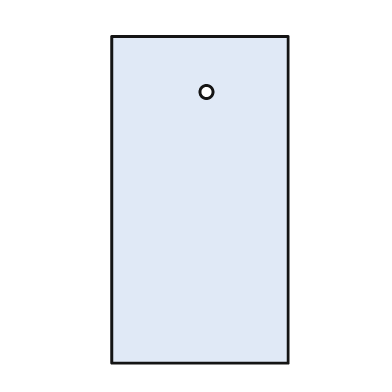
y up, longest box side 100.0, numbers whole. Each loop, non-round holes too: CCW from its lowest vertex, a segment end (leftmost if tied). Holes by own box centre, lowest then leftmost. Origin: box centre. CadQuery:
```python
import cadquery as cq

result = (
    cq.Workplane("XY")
    .moveTo(-27.0, -50.0)
    .lineTo(27.0, -50.0)
    .lineTo(27.0, 50.0)
    .lineTo(-27.0, 50.0)
    .close()
    .moveTo(2.0, 33.0)
    .circle(2.0)
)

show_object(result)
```